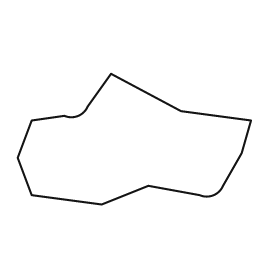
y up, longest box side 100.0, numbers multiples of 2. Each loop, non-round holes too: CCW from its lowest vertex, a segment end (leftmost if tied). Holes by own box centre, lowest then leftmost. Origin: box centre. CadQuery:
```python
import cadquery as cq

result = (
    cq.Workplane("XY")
    .moveTo(-14.0, -28.0)
    .lineTo(6.0, -20.0)
    .lineTo(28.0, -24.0)
    .threePointArc((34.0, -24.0), (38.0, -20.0))
    .lineTo(46.0, -6.0)
    .lineTo(50.0, 8.0)
    .lineTo(20.0, 12.0)
    .lineTo(-10.0, 28.0)
    .lineTo(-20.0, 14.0)
    .threePointArc((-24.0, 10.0), (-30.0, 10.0))
    .lineTo(-44.0, 8.0)
    .lineTo(-50.0, -8.0)
    .lineTo(-44.0, -24.0)
    .close()
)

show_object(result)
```